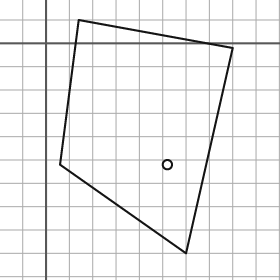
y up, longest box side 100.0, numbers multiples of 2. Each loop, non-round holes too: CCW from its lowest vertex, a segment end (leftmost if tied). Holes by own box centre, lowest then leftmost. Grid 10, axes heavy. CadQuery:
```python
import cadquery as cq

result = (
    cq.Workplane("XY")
    .moveTo(60.0, -90.0)
    .lineTo(80.0, -2.0)
    .lineTo(14.0, 10.0)
    .lineTo(6.0, -52.0)
    .close()
    .moveTo(52.0, -52.0)
    .circle(2.0)
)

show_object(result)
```